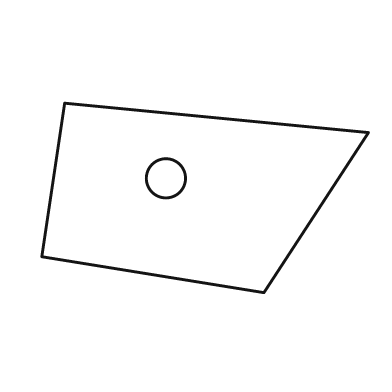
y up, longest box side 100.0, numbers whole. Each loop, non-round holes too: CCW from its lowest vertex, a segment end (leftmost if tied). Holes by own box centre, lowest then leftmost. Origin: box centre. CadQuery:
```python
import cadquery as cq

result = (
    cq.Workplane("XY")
    .moveTo(18.0, -29.0)
    .lineTo(50.0, 20.0)
    .lineTo(-43.0, 29.0)
    .lineTo(-50.0, -18.0)
    .close()
    .moveTo(-12.0, 6.0)
    .circle(6.0)
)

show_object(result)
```